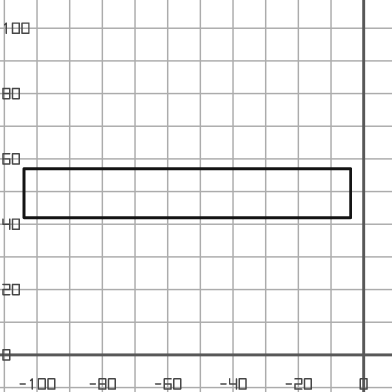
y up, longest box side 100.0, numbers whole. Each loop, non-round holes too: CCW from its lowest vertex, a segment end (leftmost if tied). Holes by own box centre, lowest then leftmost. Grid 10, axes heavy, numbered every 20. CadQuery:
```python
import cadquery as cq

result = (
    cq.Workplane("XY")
    .moveTo(-104.0, 42.0)
    .lineTo(-4.0, 42.0)
    .lineTo(-4.0, 57.0)
    .lineTo(-104.0, 57.0)
    .close()
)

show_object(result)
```